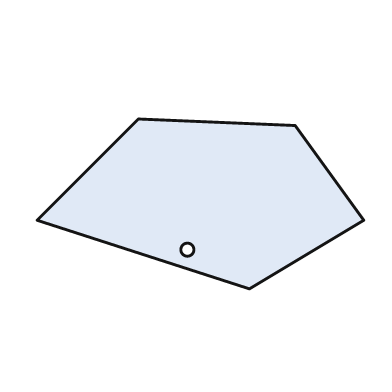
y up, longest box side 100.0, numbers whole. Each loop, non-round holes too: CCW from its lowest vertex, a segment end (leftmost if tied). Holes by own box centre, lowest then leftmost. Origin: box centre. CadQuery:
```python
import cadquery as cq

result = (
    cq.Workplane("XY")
    .moveTo(15.0, -26.0)
    .lineTo(50.0, -5.0)
    .lineTo(29.0, 24.0)
    .lineTo(-19.0, 26.0)
    .lineTo(-50.0, -5.0)
    .close()
    .moveTo(-4.0, -14.0)
    .circle(2.0)
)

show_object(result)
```